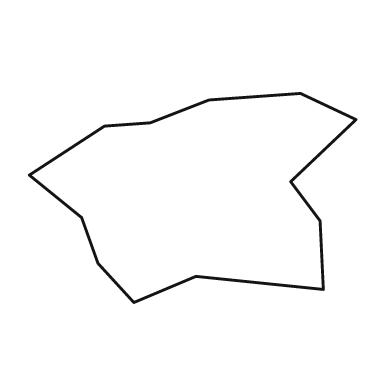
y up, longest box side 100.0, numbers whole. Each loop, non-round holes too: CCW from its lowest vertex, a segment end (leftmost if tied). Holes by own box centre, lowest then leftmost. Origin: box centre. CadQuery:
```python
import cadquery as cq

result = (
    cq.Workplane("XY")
    .moveTo(-18.0, -32.0)
    .lineTo(1.0, -24.0)
    .lineTo(40.0, -28.0)
    .lineTo(39.0, -7.0)
    .lineTo(30.0, 5.0)
    .lineTo(50.0, 24.0)
    .lineTo(33.0, 32.0)
    .lineTo(5.0, 30.0)
    .lineTo(-13.0, 23.0)
    .lineTo(-27.0, 22.0)
    .lineTo(-50.0, 7.0)
    .lineTo(-34.0, -6.0)
    .lineTo(-29.0, -20.0)
    .close()
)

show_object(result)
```